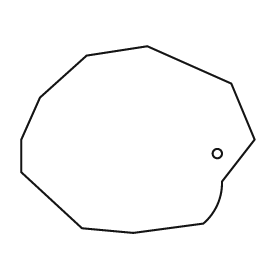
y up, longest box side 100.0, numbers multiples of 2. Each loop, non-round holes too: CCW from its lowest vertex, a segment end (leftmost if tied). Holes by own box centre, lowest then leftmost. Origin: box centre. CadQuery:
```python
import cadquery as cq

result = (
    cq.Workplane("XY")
    .moveTo(-2.0, -40.0)
    .lineTo(28.0, -36.0)
    .threePointArc((34.0, -28.0), (36.0, -18.0))
    .lineTo(50.0, 0.0)
    .lineTo(40.0, 24.0)
    .lineTo(4.0, 40.0)
    .lineTo(-22.0, 36.0)
    .lineTo(-42.0, 18.0)
    .lineTo(-50.0, 0.0)
    .lineTo(-50.0, -14.0)
    .lineTo(-24.0, -38.0)
    .close()
    .moveTo(34.0, -6.0)
    .circle(2.0)
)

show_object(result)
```